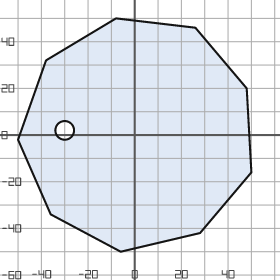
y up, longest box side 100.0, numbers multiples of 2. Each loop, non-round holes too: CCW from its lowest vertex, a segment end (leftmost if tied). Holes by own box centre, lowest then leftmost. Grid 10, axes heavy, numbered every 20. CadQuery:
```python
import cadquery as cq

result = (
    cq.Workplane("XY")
    .moveTo(-6.0, -50.0)
    .lineTo(28.0, -42.0)
    .lineTo(50.0, -16.0)
    .lineTo(48.0, 20.0)
    .lineTo(26.0, 46.0)
    .lineTo(-8.0, 50.0)
    .lineTo(-38.0, 32.0)
    .lineTo(-50.0, -2.0)
    .lineTo(-36.0, -34.0)
    .close()
    .moveTo(-30.0, 2.0)
    .circle(4.0)
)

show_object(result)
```